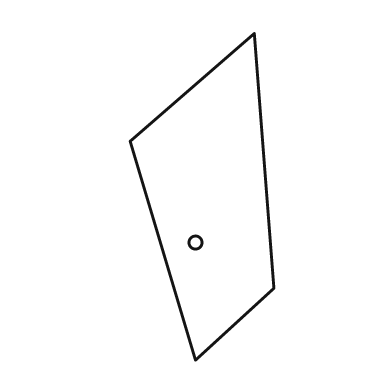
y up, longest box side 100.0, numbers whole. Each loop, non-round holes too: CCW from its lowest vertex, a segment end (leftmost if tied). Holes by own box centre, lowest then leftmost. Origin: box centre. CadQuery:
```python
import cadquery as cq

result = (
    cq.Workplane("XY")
    .moveTo(-2.0, -50.0)
    .lineTo(22.0, -28.0)
    .lineTo(16.0, 50.0)
    .lineTo(-22.0, 17.0)
    .close()
    .moveTo(-2.0, -14.0)
    .circle(2.0)
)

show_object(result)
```